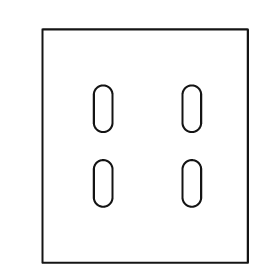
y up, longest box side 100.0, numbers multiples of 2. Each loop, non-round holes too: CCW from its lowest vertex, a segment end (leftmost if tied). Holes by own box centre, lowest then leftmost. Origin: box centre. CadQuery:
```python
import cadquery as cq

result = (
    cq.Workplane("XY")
    .moveTo(-44.0, -50.0)
    .lineTo(44.0, -50.0)
    .lineTo(44.0, 50.0)
    .lineTo(-44.0, 50.0)
    .close()
    .moveTo(-22.0, -22.0)
    .threePointArc((-18.0, -26.0), (-14.0, -22.0))
    .lineTo(-14.0, -10.0)
    .threePointArc((-18.0, -6.0), (-22.0, -10.0))
    .close()
    .moveTo(16.0, -22.0)
    .threePointArc((20.0, -26.0), (24.0, -22.0))
    .lineTo(24.0, -10.0)
    .threePointArc((20.0, -6.0), (16.0, -10.0))
    .close()
    .moveTo(-22.0, 10.0)
    .threePointArc((-18.0, 6.0), (-14.0, 10.0))
    .lineTo(-14.0, 22.0)
    .threePointArc((-18.0, 26.0), (-22.0, 22.0))
    .close()
    .moveTo(16.0, 10.0)
    .threePointArc((20.0, 6.0), (24.0, 10.0))
    .lineTo(24.0, 22.0)
    .threePointArc((20.0, 26.0), (16.0, 22.0))
    .close()
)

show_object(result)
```